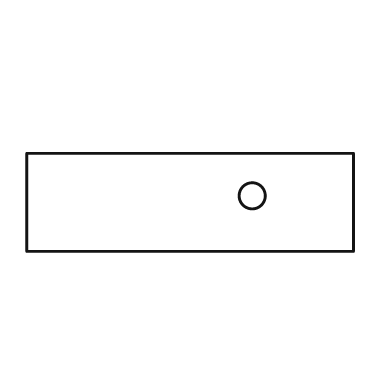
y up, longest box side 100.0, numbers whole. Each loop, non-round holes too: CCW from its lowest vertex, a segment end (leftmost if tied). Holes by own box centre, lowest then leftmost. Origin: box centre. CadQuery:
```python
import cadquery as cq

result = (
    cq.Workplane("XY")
    .moveTo(-50.0, -15.0)
    .lineTo(50.0, -15.0)
    .lineTo(50.0, 15.0)
    .lineTo(-50.0, 15.0)
    .close()
    .moveTo(19.0, 2.0)
    .circle(4.0)
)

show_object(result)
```